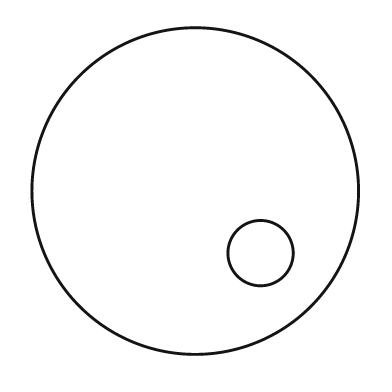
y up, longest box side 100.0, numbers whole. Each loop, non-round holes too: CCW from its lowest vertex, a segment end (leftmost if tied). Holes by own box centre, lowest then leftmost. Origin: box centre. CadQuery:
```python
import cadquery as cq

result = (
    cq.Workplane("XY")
    .moveTo(0.0, 0.0)
    .circle(50.0)
    .moveTo(20.0, -19.0)
    .circle(10.0)
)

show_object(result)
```